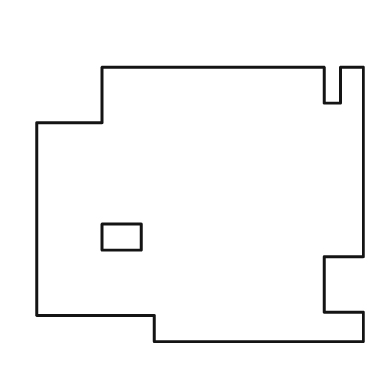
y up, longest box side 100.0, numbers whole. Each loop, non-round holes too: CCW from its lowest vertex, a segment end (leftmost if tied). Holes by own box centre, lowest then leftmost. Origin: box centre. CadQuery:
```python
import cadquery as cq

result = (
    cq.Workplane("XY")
    .moveTo(-14.0, -42.0)
    .lineTo(50.0, -42.0)
    .lineTo(50.0, -33.0)
    .lineTo(38.0, -33.0)
    .lineTo(38.0, -16.0)
    .lineTo(50.0, -16.0)
    .lineTo(50.0, 42.0)
    .lineTo(43.0, 42.0)
    .lineTo(43.0, 31.0)
    .lineTo(38.0, 31.0)
    .lineTo(38.0, 42.0)
    .lineTo(-30.0, 42.0)
    .lineTo(-30.0, 25.0)
    .lineTo(-50.0, 25.0)
    .lineTo(-50.0, -34.0)
    .lineTo(-14.0, -34.0)
    .close()
    .moveTo(-30.0, -14.0)
    .lineTo(-18.0, -14.0)
    .lineTo(-18.0, -6.0)
    .lineTo(-30.0, -6.0)
    .close()
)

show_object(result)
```